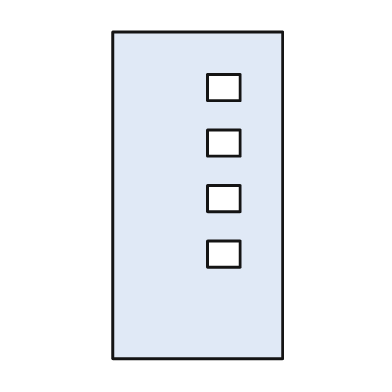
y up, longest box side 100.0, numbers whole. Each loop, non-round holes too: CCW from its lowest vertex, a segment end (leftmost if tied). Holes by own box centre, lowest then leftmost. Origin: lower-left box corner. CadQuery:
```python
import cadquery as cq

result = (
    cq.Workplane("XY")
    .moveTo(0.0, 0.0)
    .lineTo(52.0, 0.0)
    .lineTo(52.0, 100.0)
    .lineTo(0.0, 100.0)
    .close()
    .moveTo(29.0, 28.0)
    .lineTo(39.0, 28.0)
    .lineTo(39.0, 36.0)
    .lineTo(29.0, 36.0)
    .close()
    .moveTo(29.0, 45.0)
    .lineTo(39.0, 45.0)
    .lineTo(39.0, 53.0)
    .lineTo(29.0, 53.0)
    .close()
    .moveTo(29.0, 62.0)
    .lineTo(39.0, 62.0)
    .lineTo(39.0, 70.0)
    .lineTo(29.0, 70.0)
    .close()
    .moveTo(29.0, 79.0)
    .lineTo(39.0, 79.0)
    .lineTo(39.0, 87.0)
    .lineTo(29.0, 87.0)
    .close()
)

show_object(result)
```